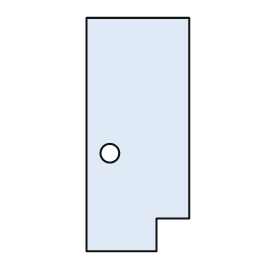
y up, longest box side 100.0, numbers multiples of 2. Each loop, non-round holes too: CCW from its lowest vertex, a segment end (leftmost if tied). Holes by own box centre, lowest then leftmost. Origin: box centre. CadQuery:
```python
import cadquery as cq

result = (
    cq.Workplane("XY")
    .moveTo(-22.0, -50.0)
    .lineTo(8.0, -50.0)
    .lineTo(8.0, -36.0)
    .lineTo(22.0, -36.0)
    .lineTo(22.0, 50.0)
    .lineTo(-22.0, 50.0)
    .close()
    .moveTo(-12.0, -8.0)
    .circle(4.0)
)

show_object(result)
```